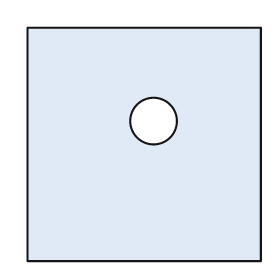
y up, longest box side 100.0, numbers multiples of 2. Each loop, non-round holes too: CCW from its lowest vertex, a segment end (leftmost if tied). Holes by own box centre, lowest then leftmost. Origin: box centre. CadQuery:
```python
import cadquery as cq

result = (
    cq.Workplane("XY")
    .moveTo(-50.0, -50.0)
    .lineTo(50.0, -50.0)
    .lineTo(50.0, 50.0)
    .lineTo(-50.0, 50.0)
    .close()
    .moveTo(4.0, 10.0)
    .circle(10.0)
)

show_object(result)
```